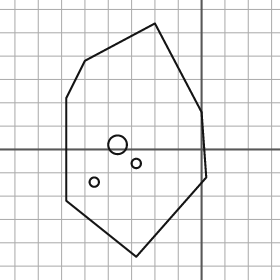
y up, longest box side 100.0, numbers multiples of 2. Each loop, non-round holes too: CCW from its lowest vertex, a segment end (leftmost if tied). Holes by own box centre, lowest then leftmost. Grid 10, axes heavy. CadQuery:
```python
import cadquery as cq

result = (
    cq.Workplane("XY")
    .moveTo(-28.0, -46.0)
    .lineTo(2.0, -12.0)
    .lineTo(0.0, 16.0)
    .lineTo(-20.0, 54.0)
    .lineTo(-50.0, 38.0)
    .lineTo(-58.0, 22.0)
    .lineTo(-58.0, -22.0)
    .close()
    .moveTo(-46.0, -14.0)
    .circle(2.0)
    .moveTo(-28.0, -6.0)
    .circle(2.0)
    .moveTo(-36.0, 2.0)
    .circle(4.0)
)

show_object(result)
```